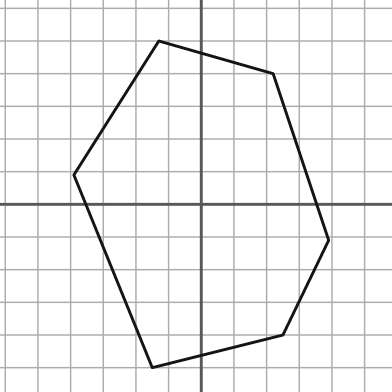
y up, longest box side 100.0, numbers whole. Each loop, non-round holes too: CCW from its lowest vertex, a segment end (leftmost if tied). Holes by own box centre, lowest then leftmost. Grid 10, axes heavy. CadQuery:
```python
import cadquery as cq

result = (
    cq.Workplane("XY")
    .moveTo(-15.0, -50.0)
    .lineTo(25.0, -40.0)
    .lineTo(39.0, -11.0)
    .lineTo(22.0, 40.0)
    .lineTo(-13.0, 50.0)
    .lineTo(-39.0, 9.0)
    .close()
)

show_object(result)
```